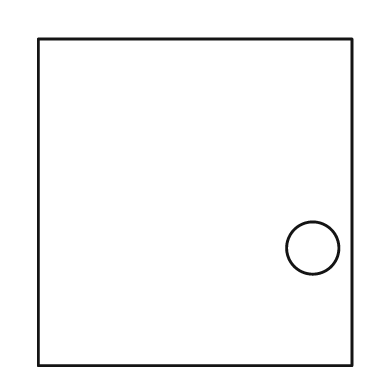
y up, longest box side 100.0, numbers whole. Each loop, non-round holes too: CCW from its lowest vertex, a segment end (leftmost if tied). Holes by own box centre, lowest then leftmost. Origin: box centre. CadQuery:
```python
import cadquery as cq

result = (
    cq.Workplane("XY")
    .moveTo(-48.0, -50.0)
    .lineTo(48.0, -50.0)
    .lineTo(48.0, 50.0)
    .lineTo(-48.0, 50.0)
    .close()
    .moveTo(36.0, -14.0)
    .circle(8.0)
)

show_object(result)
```